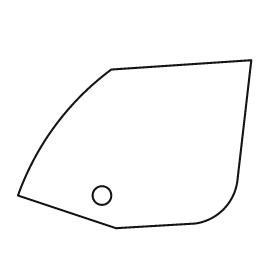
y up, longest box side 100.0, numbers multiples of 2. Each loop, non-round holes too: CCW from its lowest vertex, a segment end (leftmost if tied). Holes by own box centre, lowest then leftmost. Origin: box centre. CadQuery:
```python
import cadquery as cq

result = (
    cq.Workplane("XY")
    .moveTo(-8.0, -36.0)
    .lineTo(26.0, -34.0)
    .threePointArc((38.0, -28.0), (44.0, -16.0))
    .lineTo(50.0, 36.0)
    .lineTo(-10.0, 32.0)
    .threePointArc((-34.0, 8.0), (-50.0, -22.0))
    .close()
    .moveTo(-14.0, -22.0)
    .circle(4.0)
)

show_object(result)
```